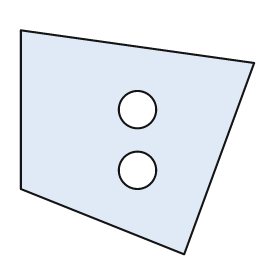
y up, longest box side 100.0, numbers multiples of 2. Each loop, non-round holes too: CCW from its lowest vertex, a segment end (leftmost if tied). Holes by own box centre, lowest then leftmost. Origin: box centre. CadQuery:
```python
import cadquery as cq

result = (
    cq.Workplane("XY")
    .moveTo(20.0, -48.0)
    .lineTo(50.0, 34.0)
    .lineTo(-50.0, 48.0)
    .lineTo(-50.0, -20.0)
    .close()
    .moveTo(0.0, -12.0)
    .circle(8.0)
    .moveTo(0.0, 14.0)
    .circle(8.0)
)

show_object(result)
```